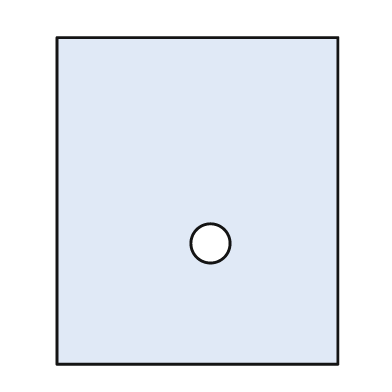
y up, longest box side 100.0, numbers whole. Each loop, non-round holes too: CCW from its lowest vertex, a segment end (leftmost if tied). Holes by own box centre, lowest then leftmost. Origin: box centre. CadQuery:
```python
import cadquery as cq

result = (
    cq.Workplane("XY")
    .moveTo(-43.0, -50.0)
    .lineTo(43.0, -50.0)
    .lineTo(43.0, 50.0)
    .lineTo(-43.0, 50.0)
    .close()
    .moveTo(4.0, -13.0)
    .circle(6.0)
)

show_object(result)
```